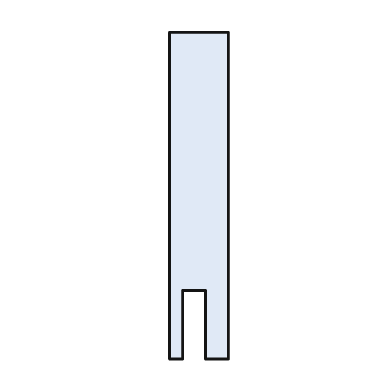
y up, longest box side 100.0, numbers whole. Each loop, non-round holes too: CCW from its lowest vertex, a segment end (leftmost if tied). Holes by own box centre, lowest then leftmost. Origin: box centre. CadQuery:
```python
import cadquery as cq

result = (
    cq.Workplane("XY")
    .moveTo(-9.0, -50.0)
    .lineTo(-5.0, -50.0)
    .lineTo(-5.0, -29.0)
    .lineTo(2.0, -29.0)
    .lineTo(2.0, -50.0)
    .lineTo(9.0, -50.0)
    .lineTo(9.0, 50.0)
    .lineTo(-9.0, 50.0)
    .close()
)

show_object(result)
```